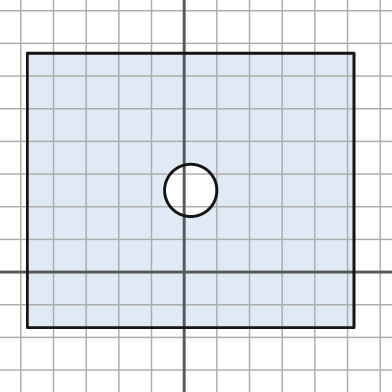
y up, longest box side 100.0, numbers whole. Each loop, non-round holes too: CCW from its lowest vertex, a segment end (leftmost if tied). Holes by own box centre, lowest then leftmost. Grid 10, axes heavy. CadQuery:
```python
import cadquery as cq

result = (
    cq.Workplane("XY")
    .moveTo(-48.0, -17.0)
    .lineTo(52.0, -17.0)
    .lineTo(52.0, 67.0)
    .lineTo(-48.0, 67.0)
    .close()
    .moveTo(2.0, 25.0)
    .circle(8.0)
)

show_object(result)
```